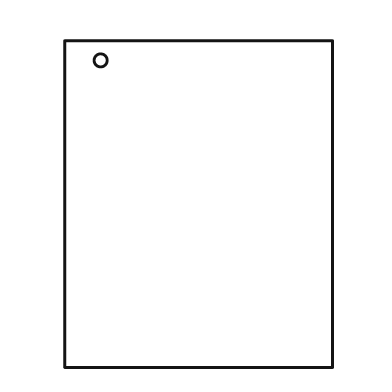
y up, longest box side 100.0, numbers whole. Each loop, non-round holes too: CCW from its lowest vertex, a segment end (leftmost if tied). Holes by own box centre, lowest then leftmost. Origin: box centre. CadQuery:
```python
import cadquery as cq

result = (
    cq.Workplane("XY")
    .moveTo(-41.0, -50.0)
    .lineTo(41.0, -50.0)
    .lineTo(41.0, 50.0)
    .lineTo(-41.0, 50.0)
    .close()
    .moveTo(-30.0, 44.0)
    .circle(2.0)
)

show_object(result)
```